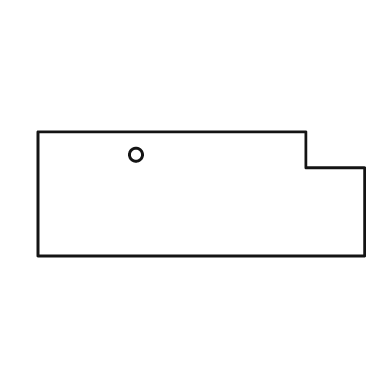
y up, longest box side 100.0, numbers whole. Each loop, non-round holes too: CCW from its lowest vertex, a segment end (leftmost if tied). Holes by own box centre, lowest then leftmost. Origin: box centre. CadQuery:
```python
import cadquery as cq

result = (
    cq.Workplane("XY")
    .moveTo(-50.0, -19.0)
    .lineTo(50.0, -19.0)
    .lineTo(50.0, 8.0)
    .lineTo(32.0, 8.0)
    .lineTo(32.0, 19.0)
    .lineTo(-50.0, 19.0)
    .close()
    .moveTo(-20.0, 12.0)
    .circle(2.0)
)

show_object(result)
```